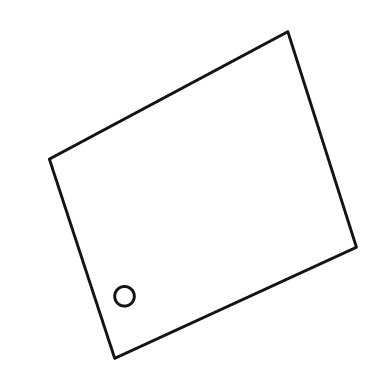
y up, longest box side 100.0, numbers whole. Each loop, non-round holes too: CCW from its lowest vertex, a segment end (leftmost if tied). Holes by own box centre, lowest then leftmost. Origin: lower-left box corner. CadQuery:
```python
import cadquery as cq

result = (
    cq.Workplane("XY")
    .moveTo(20.0, 0.0)
    .lineTo(94.0, 34.0)
    .lineTo(73.0, 100.0)
    .lineTo(0.0, 61.0)
    .close()
    .moveTo(23.0, 19.0)
    .circle(3.0)
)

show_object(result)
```